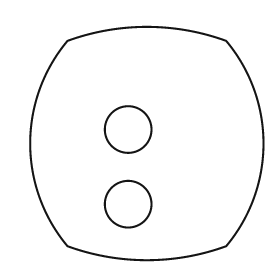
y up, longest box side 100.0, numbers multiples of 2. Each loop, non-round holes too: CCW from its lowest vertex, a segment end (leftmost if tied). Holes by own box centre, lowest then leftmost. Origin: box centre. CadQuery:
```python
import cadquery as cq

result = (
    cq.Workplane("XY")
    .moveTo(-34.0, -44.0)
    .threePointArc((0.0, -50.0), (34.0, -44.0))
    .threePointArc((50.0, 0.0), (34.0, 44.0))
    .threePointArc((0.0, 50.0), (-34.0, 44.0))
    .threePointArc((-50.0, 0.0), (-34.0, -44.0))
    .close()
    .moveTo(-8.0, -26.0)
    .circle(10.0)
    .moveTo(-8.0, 6.0)
    .circle(10.0)
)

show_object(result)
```